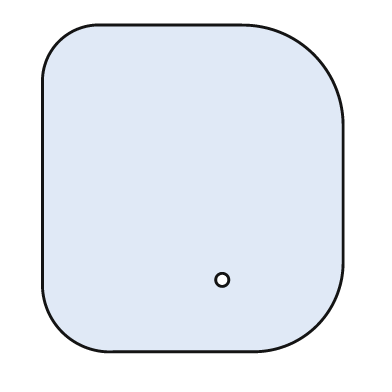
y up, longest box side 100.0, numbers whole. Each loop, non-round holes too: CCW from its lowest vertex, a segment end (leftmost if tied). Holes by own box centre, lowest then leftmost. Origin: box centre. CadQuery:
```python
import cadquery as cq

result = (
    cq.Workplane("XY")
    .moveTo(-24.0, -50.0)
    .lineTo(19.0, -50.0)
    .threePointArc((38.0, -42.0), (46.0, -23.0))
    .lineTo(46.0, 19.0)
    .threePointArc((37.0, 41.0), (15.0, 50.0))
    .lineTo(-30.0, 50.0)
    .threePointArc((-41.0, 45.0), (-46.0, 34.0))
    .lineTo(-46.0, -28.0)
    .threePointArc((-40.0, -44.0), (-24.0, -50.0))
    .close()
    .moveTo(9.0, -28.0)
    .circle(2.0)
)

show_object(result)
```